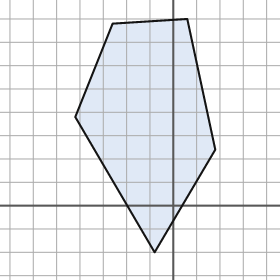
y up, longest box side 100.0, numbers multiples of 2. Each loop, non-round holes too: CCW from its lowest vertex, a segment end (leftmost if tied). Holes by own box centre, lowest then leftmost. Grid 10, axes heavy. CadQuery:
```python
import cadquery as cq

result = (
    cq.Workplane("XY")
    .moveTo(-8.0, -20.0)
    .lineTo(18.0, 24.0)
    .lineTo(6.0, 80.0)
    .lineTo(-26.0, 78.0)
    .lineTo(-42.0, 38.0)
    .close()
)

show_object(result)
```